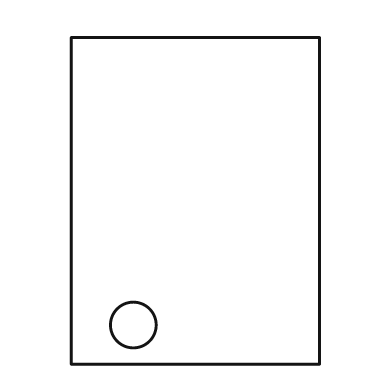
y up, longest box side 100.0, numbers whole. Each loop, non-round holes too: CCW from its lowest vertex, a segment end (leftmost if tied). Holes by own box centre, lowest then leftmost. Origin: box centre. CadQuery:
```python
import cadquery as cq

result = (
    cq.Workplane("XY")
    .moveTo(-38.0, -50.0)
    .lineTo(38.0, -50.0)
    .lineTo(38.0, 50.0)
    .lineTo(-38.0, 50.0)
    .close()
    .moveTo(-19.0, -38.0)
    .circle(7.0)
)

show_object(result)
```